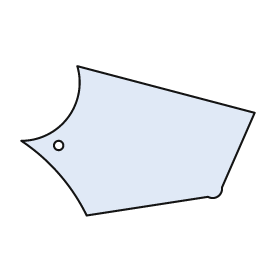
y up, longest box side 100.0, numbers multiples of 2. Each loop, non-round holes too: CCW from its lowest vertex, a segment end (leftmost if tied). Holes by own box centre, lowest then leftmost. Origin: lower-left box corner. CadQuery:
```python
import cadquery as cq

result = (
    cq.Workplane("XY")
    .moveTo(28.0, 0.0)
    .lineTo(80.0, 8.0)
    .threePointArc((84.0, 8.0), (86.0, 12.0))
    .lineTo(100.0, 44.0)
    .lineTo(24.0, 64.0)
    .threePointArc((20.0, 42.0), (0.0, 32.0))
    .threePointArc((16.0, 18.0), (28.0, 0.0))
    .close()
    .moveTo(16.0, 30.0)
    .circle(2.0)
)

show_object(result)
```